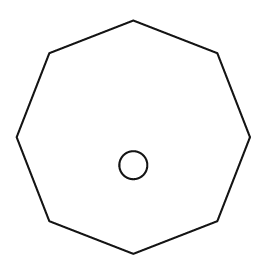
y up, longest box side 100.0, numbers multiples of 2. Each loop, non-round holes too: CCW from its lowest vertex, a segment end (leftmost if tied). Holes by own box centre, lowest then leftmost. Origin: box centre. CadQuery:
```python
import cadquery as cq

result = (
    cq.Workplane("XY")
    .moveTo(0.0, -50.0)
    .lineTo(36.0, -36.0)
    .lineTo(50.0, 0.0)
    .lineTo(36.0, 36.0)
    .lineTo(0.0, 50.0)
    .lineTo(-36.0, 36.0)
    .lineTo(-50.0, 0.0)
    .lineTo(-36.0, -36.0)
    .close()
    .moveTo(0.0, -12.0)
    .circle(6.0)
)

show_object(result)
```